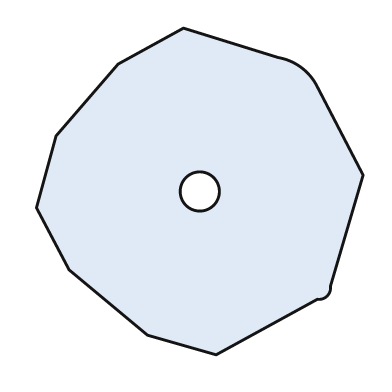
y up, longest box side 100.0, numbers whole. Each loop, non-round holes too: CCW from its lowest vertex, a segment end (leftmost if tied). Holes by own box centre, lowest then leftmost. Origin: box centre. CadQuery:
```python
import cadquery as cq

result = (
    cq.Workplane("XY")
    .moveTo(5.0, -50.0)
    .lineTo(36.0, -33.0)
    .threePointArc((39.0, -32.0), (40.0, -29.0))
    .lineTo(50.0, 5.0)
    .lineTo(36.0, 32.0)
    .threePointArc((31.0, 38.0), (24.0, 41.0))
    .lineTo(-5.0, 50.0)
    .lineTo(-25.0, 39.0)
    .lineTo(-44.0, 17.0)
    .lineTo(-50.0, -5.0)
    .lineTo(-40.0, -24.0)
    .lineTo(-16.0, -44.0)
    .close()
    .moveTo(0.0, 0.0)
    .circle(6.0)
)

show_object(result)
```